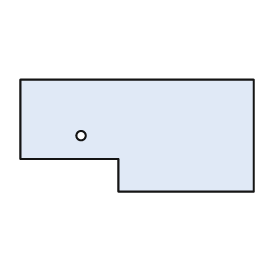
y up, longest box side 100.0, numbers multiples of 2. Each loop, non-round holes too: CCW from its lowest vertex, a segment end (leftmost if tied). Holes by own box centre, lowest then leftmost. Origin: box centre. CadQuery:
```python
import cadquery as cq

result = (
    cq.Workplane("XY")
    .moveTo(-8.0, -24.0)
    .lineTo(50.0, -24.0)
    .lineTo(50.0, 24.0)
    .lineTo(-50.0, 24.0)
    .lineTo(-50.0, -10.0)
    .lineTo(-8.0, -10.0)
    .close()
    .moveTo(-24.0, 0.0)
    .circle(2.0)
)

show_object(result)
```